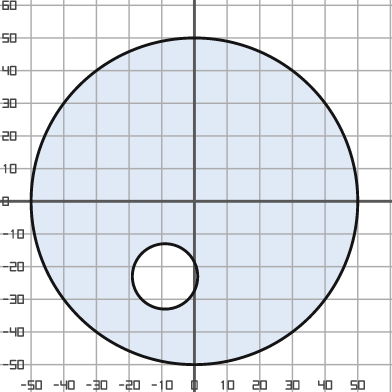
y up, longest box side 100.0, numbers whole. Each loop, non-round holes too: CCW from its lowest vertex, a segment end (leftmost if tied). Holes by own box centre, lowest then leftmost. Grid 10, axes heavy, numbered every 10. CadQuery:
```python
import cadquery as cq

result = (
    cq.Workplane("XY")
    .moveTo(0.0, 0.0)
    .circle(50.0)
    .moveTo(-9.0, -23.0)
    .circle(10.0)
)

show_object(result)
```